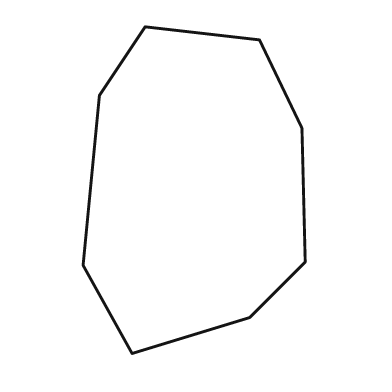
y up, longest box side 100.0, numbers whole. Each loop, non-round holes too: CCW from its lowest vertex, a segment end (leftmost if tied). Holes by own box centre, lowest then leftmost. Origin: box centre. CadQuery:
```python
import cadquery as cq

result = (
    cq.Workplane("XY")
    .moveTo(-19.0, -50.0)
    .lineTo(17.0, -39.0)
    .lineTo(34.0, -22.0)
    .lineTo(33.0, 19.0)
    .lineTo(20.0, 46.0)
    .lineTo(-15.0, 50.0)
    .lineTo(-29.0, 29.0)
    .lineTo(-34.0, -23.0)
    .close()
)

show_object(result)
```